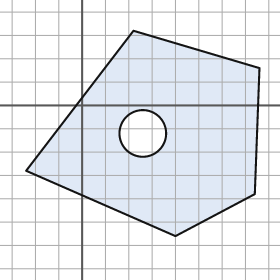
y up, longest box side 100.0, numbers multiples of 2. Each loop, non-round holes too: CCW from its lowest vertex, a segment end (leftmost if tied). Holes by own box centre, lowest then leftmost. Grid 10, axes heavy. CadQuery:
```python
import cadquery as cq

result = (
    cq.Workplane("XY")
    .moveTo(40.0, -56.0)
    .lineTo(74.0, -38.0)
    .lineTo(76.0, 16.0)
    .lineTo(22.0, 32.0)
    .lineTo(-24.0, -28.0)
    .close()
    .moveTo(26.0, -12.0)
    .circle(10.0)
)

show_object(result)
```